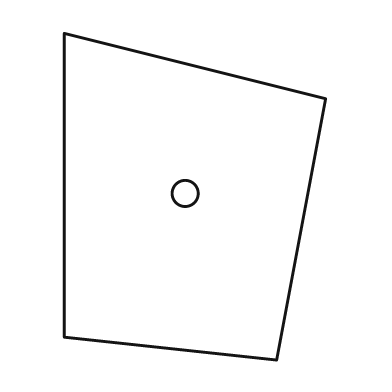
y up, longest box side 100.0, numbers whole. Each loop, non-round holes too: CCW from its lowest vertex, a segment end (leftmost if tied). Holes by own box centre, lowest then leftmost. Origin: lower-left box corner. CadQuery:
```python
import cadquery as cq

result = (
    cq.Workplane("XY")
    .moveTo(65.0, 0.0)
    .lineTo(80.0, 80.0)
    .lineTo(0.0, 100.0)
    .lineTo(0.0, 7.0)
    .close()
    .moveTo(37.0, 51.0)
    .circle(4.0)
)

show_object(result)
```